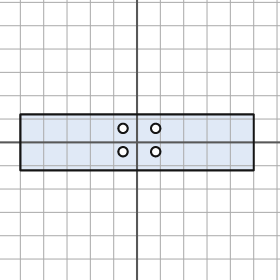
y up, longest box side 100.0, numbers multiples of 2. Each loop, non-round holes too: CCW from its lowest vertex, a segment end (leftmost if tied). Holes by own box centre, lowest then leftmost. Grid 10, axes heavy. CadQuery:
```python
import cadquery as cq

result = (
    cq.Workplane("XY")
    .moveTo(-50.0, -12.0)
    .lineTo(50.0, -12.0)
    .lineTo(50.0, 12.0)
    .lineTo(-50.0, 12.0)
    .close()
    .moveTo(-6.0, -4.0)
    .circle(2.0)
    .moveTo(8.0, -4.0)
    .circle(2.0)
    .moveTo(-6.0, 6.0)
    .circle(2.0)
    .moveTo(8.0, 6.0)
    .circle(2.0)
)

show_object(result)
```